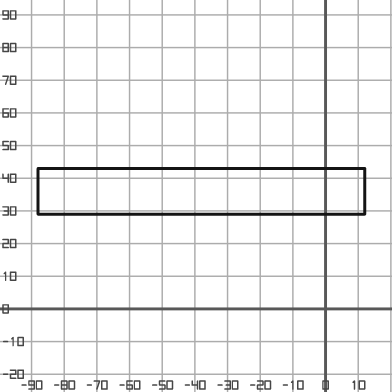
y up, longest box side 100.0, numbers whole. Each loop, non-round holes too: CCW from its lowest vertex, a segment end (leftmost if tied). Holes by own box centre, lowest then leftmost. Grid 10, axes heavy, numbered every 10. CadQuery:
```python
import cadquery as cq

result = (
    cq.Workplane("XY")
    .moveTo(-88.0, 29.0)
    .lineTo(12.0, 29.0)
    .lineTo(12.0, 43.0)
    .lineTo(-88.0, 43.0)
    .close()
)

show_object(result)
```